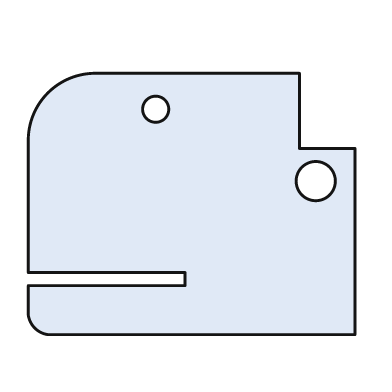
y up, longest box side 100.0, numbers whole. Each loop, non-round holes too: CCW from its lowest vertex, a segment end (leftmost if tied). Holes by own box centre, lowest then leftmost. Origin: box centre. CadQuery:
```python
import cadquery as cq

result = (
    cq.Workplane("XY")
    .moveTo(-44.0, -40.0)
    .lineTo(50.0, -40.0)
    .lineTo(50.0, 17.0)
    .lineTo(33.0, 17.0)
    .lineTo(33.0, 40.0)
    .lineTo(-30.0, 40.0)
    .threePointArc((-44.0, 34.0), (-50.0, 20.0))
    .lineTo(-50.0, -21.0)
    .lineTo(-2.0, -21.0)
    .lineTo(-2.0, -25.0)
    .lineTo(-50.0, -25.0)
    .lineTo(-50.0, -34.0)
    .threePointArc((-48.0, -38.0), (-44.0, -40.0))
    .close()
    .moveTo(38.0, 7.0)
    .circle(6.0)
    .moveTo(-11.0, 29.0)
    .circle(4.0)
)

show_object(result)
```